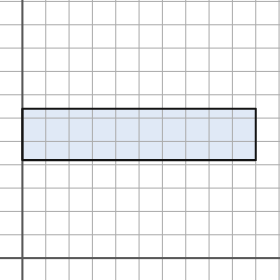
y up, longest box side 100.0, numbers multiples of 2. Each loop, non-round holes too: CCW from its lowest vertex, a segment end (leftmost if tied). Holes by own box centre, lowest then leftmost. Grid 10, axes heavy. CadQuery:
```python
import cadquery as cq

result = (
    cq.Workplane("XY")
    .moveTo(0.0, 42.0)
    .lineTo(100.0, 42.0)
    .lineTo(100.0, 64.0)
    .lineTo(0.0, 64.0)
    .close()
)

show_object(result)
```